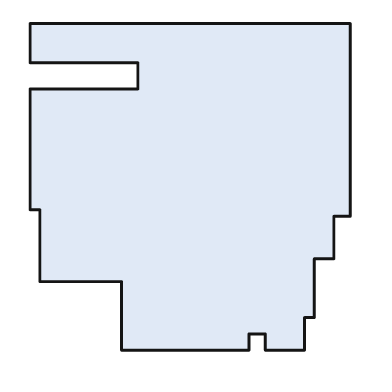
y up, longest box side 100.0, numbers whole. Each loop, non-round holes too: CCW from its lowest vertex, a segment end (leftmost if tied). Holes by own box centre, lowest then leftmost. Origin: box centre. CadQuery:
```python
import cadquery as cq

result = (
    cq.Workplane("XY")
    .moveTo(-21.0, -50.0)
    .lineTo(18.0, -50.0)
    .lineTo(18.0, -45.0)
    .lineTo(23.0, -45.0)
    .lineTo(23.0, -50.0)
    .lineTo(35.0, -50.0)
    .lineTo(35.0, -40.0)
    .lineTo(38.0, -40.0)
    .lineTo(38.0, -22.0)
    .lineTo(44.0, -22.0)
    .lineTo(44.0, -9.0)
    .lineTo(49.0, -9.0)
    .lineTo(49.0, 50.0)
    .lineTo(-49.0, 50.0)
    .lineTo(-49.0, 38.0)
    .lineTo(-16.0, 38.0)
    .lineTo(-16.0, 30.0)
    .lineTo(-49.0, 30.0)
    .lineTo(-49.0, -7.0)
    .lineTo(-46.0, -7.0)
    .lineTo(-46.0, -29.0)
    .lineTo(-21.0, -29.0)
    .close()
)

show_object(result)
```